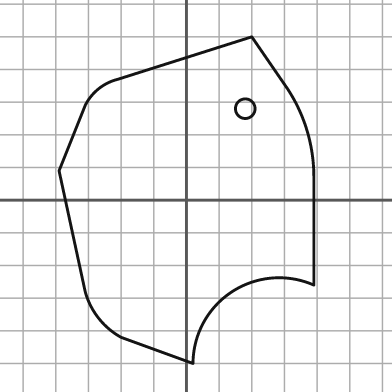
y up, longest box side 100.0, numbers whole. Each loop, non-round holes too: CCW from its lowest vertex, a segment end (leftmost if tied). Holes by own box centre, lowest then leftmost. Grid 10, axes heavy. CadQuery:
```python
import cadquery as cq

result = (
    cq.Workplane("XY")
    .moveTo(2.0, -50.0)
    .threePointArc((14.0, -28.0), (39.0, -26.0))
    .lineTo(39.0, 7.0)
    .threePointArc((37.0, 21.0), (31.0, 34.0))
    .lineTo(20.0, 50.0)
    .lineTo(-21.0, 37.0)
    .threePointArc((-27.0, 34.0), (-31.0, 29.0))
    .lineTo(-39.0, 9.0)
    .lineTo(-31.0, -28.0)
    .threePointArc((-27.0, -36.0), (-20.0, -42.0))
    .close()
    .moveTo(18.0, 28.0)
    .circle(3.0)
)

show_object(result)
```